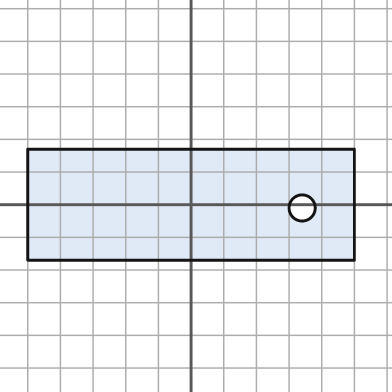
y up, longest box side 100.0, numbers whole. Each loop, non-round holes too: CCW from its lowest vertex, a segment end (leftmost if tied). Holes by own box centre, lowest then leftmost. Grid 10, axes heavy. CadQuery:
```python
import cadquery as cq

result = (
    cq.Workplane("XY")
    .moveTo(-50.0, -17.0)
    .lineTo(50.0, -17.0)
    .lineTo(50.0, 17.0)
    .lineTo(-50.0, 17.0)
    .close()
    .moveTo(34.0, -1.0)
    .circle(4.0)
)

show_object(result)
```